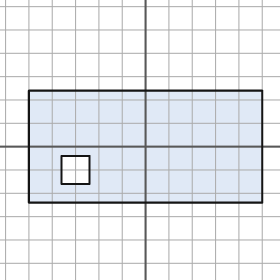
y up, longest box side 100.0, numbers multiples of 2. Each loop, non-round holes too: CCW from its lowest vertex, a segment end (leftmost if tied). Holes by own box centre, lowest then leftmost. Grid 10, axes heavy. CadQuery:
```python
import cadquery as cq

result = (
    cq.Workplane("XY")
    .moveTo(-50.0, -24.0)
    .lineTo(50.0, -24.0)
    .lineTo(50.0, 24.0)
    .lineTo(-50.0, 24.0)
    .close()
    .moveTo(-36.0, -16.0)
    .lineTo(-24.0, -16.0)
    .lineTo(-24.0, -4.0)
    .lineTo(-36.0, -4.0)
    .close()
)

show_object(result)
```